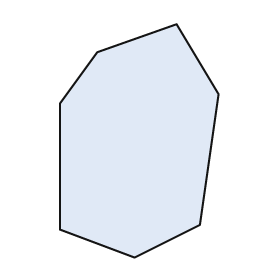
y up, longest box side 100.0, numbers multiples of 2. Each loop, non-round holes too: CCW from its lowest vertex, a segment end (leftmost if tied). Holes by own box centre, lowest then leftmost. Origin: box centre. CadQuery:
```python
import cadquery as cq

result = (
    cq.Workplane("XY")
    .moveTo(-2.0, -50.0)
    .lineTo(26.0, -36.0)
    .lineTo(34.0, 20.0)
    .lineTo(16.0, 50.0)
    .lineTo(-18.0, 38.0)
    .lineTo(-34.0, 16.0)
    .lineTo(-34.0, -38.0)
    .close()
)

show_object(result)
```